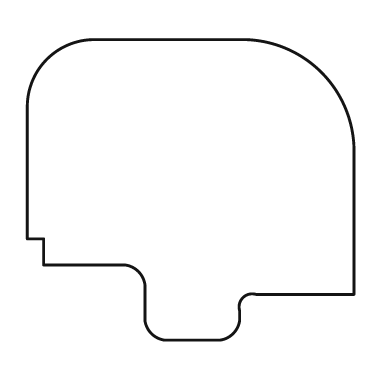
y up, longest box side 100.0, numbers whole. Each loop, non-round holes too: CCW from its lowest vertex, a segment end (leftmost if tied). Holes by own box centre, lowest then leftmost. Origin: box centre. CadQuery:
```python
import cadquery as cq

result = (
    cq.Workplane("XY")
    .moveTo(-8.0, -46.0)
    .lineTo(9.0, -46.0)
    .threePointArc((13.0, -44.0), (15.0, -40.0))
    .lineTo(15.0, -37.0)
    .threePointArc((16.0, -33.0), (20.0, -32.0))
    .lineTo(50.0, -32.0)
    .lineTo(50.0, 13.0)
    .threePointArc((40.0, 36.0), (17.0, 46.0))
    .lineTo(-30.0, 46.0)
    .threePointArc((-44.0, 40.0), (-50.0, 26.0))
    .lineTo(-50.0, -15.0)
    .lineTo(-45.0, -15.0)
    .lineTo(-45.0, -23.0)
    .lineTo(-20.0, -23.0)
    .threePointArc((-16.0, -25.0), (-14.0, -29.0))
    .lineTo(-14.0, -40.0)
    .threePointArc((-12.0, -44.0), (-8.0, -46.0))
    .close()
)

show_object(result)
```